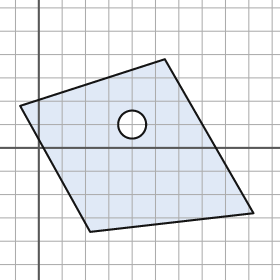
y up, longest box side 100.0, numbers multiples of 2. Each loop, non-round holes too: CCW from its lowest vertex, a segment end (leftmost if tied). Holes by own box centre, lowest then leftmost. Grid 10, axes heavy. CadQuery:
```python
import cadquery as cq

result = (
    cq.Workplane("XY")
    .moveTo(22.0, -36.0)
    .lineTo(92.0, -28.0)
    .lineTo(54.0, 38.0)
    .lineTo(-8.0, 18.0)
    .close()
    .moveTo(40.0, 10.0)
    .circle(6.0)
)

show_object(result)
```